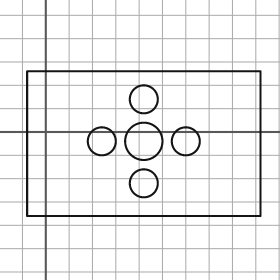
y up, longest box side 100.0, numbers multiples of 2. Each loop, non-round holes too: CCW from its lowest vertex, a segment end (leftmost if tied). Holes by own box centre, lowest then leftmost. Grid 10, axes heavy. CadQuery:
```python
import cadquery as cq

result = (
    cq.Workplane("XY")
    .moveTo(-8.0, -36.0)
    .lineTo(92.0, -36.0)
    .lineTo(92.0, 26.0)
    .lineTo(-8.0, 26.0)
    .close()
    .moveTo(42.0, -22.0)
    .circle(6.0)
    .moveTo(24.0, -4.0)
    .circle(6.0)
    .moveTo(42.0, -4.0)
    .circle(8.0)
    .moveTo(60.0, -4.0)
    .circle(6.0)
    .moveTo(42.0, 14.0)
    .circle(6.0)
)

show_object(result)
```